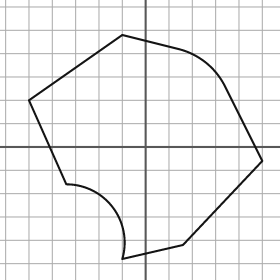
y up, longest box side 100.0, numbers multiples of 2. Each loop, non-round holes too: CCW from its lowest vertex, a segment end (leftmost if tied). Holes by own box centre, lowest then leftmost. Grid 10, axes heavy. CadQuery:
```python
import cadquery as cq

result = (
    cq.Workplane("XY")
    .moveTo(-10.0, -48.0)
    .lineTo(16.0, -42.0)
    .lineTo(50.0, -6.0)
    .lineTo(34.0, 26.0)
    .threePointArc((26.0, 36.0), (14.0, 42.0))
    .lineTo(-10.0, 48.0)
    .lineTo(-50.0, 20.0)
    .lineTo(-34.0, -16.0)
    .threePointArc((-14.0, -26.0), (-10.0, -48.0))
    .close()
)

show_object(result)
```